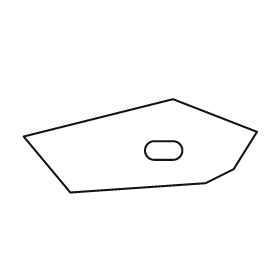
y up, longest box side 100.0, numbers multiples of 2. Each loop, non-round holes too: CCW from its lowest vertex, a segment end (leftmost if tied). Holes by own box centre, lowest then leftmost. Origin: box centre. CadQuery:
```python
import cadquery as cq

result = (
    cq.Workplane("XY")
    .moveTo(-30.0, -20.0)
    .lineTo(28.0, -16.0)
    .lineTo(40.0, -10.0)
    .lineTo(50.0, 6.0)
    .lineTo(14.0, 20.0)
    .lineTo(-50.0, 4.0)
    .close()
    .moveTo(6.0, -6.0)
    .lineTo(14.0, -6.0)
    .threePointArc((18.0, -2.0), (14.0, 2.0))
    .lineTo(6.0, 2.0)
    .threePointArc((2.0, -2.0), (6.0, -6.0))
    .close()
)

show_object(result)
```